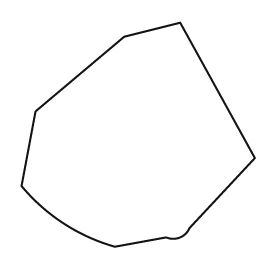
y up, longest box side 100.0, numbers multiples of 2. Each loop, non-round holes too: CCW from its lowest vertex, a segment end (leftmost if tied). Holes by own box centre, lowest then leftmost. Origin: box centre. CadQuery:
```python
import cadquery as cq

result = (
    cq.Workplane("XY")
    .moveTo(-10.0, -48.0)
    .lineTo(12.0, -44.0)
    .threePointArc((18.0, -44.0), (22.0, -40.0))
    .lineTo(50.0, -10.0)
    .lineTo(18.0, 48.0)
    .lineTo(-6.0, 42.0)
    .lineTo(-44.0, 10.0)
    .lineTo(-50.0, -22.0)
    .threePointArc((-32.0, -38.0), (-10.0, -48.0))
    .close()
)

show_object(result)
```